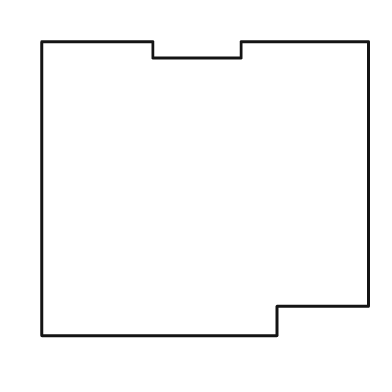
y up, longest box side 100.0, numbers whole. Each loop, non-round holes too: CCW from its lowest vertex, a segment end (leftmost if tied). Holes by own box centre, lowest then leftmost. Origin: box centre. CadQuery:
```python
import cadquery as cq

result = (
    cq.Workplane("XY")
    .moveTo(-50.0, -45.0)
    .lineTo(22.0, -45.0)
    .lineTo(22.0, -36.0)
    .lineTo(50.0, -36.0)
    .lineTo(50.0, 45.0)
    .lineTo(11.0, 45.0)
    .lineTo(11.0, 40.0)
    .lineTo(-16.0, 40.0)
    .lineTo(-16.0, 45.0)
    .lineTo(-50.0, 45.0)
    .close()
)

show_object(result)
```